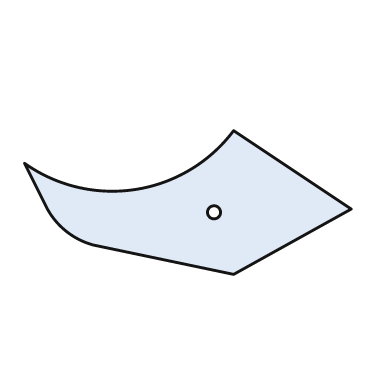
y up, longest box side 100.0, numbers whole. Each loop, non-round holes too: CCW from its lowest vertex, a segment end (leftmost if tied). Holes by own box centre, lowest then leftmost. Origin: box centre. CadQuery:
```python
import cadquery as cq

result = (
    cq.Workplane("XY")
    .moveTo(14.0, -22.0)
    .lineTo(50.0, -2.0)
    .lineTo(14.0, 22.0)
    .threePointArc((-16.0, 4.0), (-50.0, 12.0))
    .lineTo(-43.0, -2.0)
    .threePointArc((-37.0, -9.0), (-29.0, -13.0))
    .close()
    .moveTo(8.0, -3.0)
    .circle(2.0)
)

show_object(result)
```